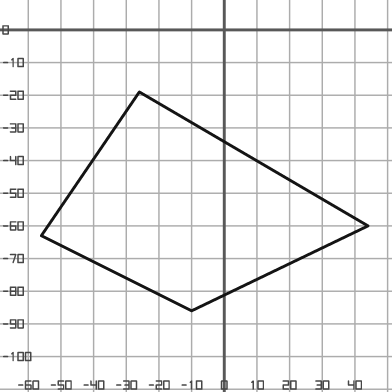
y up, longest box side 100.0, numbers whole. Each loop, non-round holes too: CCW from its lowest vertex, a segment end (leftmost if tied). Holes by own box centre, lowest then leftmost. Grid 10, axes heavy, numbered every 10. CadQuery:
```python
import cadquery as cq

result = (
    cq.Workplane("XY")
    .moveTo(-10.0, -86.0)
    .lineTo(44.0, -60.0)
    .lineTo(-26.0, -19.0)
    .lineTo(-56.0, -63.0)
    .close()
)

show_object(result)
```